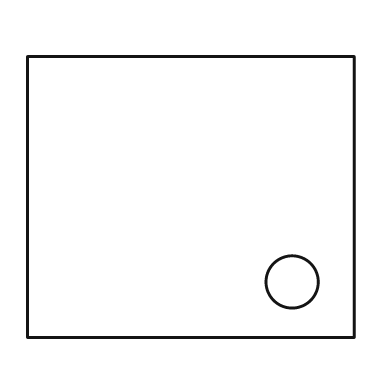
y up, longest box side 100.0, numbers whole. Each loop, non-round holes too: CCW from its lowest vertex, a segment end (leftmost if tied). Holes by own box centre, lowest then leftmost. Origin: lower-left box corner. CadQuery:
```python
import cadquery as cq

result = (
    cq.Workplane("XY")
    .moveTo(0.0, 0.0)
    .lineTo(100.0, 0.0)
    .lineTo(100.0, 86.0)
    .lineTo(0.0, 86.0)
    .close()
    .moveTo(81.0, 17.0)
    .circle(8.0)
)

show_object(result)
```